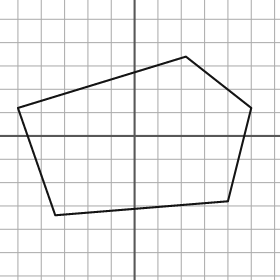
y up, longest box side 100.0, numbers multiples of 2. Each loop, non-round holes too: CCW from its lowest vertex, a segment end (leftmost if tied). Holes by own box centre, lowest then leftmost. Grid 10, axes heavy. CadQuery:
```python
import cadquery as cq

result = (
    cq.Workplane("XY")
    .moveTo(-34.0, -34.0)
    .lineTo(40.0, -28.0)
    .lineTo(50.0, 12.0)
    .lineTo(22.0, 34.0)
    .lineTo(-50.0, 12.0)
    .close()
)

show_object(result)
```